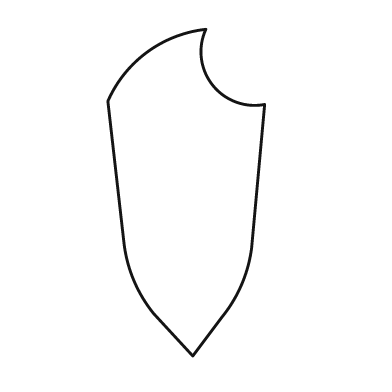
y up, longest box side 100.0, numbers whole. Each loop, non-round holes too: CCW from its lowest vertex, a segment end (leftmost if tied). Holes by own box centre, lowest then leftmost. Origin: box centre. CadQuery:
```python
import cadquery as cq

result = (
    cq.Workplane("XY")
    .moveTo(2.0, -50.0)
    .lineTo(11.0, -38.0)
    .threePointArc((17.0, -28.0), (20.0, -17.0))
    .lineTo(24.0, 27.0)
    .threePointArc((8.0, 33.0), (6.0, 50.0))
    .threePointArc((-12.0, 43.0), (-24.0, 28.0))
    .lineTo(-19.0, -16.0)
    .threePointArc((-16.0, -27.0), (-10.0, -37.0))
    .close()
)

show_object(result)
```